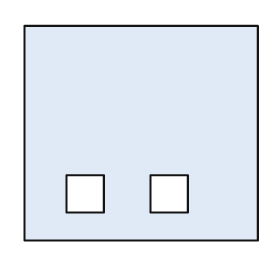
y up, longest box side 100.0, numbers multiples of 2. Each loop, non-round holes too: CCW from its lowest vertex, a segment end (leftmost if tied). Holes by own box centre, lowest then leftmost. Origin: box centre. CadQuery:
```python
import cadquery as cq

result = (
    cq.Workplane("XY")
    .moveTo(-50.0, -46.0)
    .lineTo(50.0, -46.0)
    .lineTo(50.0, 46.0)
    .lineTo(-50.0, 46.0)
    .close()
    .moveTo(-32.0, -34.0)
    .lineTo(-16.0, -34.0)
    .lineTo(-16.0, -18.0)
    .lineTo(-32.0, -18.0)
    .close()
    .moveTo(4.0, -34.0)
    .lineTo(20.0, -34.0)
    .lineTo(20.0, -18.0)
    .lineTo(4.0, -18.0)
    .close()
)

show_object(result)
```